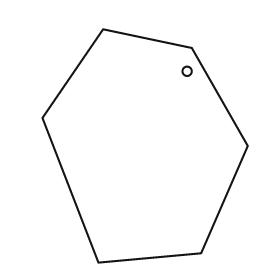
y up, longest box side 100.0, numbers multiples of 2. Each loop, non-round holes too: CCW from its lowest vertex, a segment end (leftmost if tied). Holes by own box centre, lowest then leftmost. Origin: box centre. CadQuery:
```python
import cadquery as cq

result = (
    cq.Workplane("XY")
    .moveTo(-20.0, -50.0)
    .lineTo(24.0, -46.0)
    .lineTo(44.0, 0.0)
    .lineTo(20.0, 42.0)
    .lineTo(-18.0, 50.0)
    .lineTo(-44.0, 12.0)
    .close()
    .moveTo(18.0, 32.0)
    .circle(2.0)
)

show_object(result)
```